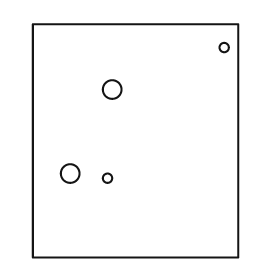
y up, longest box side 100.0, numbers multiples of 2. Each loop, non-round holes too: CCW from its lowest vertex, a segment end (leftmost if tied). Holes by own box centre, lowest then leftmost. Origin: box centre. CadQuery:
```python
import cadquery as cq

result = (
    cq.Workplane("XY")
    .moveTo(-44.0, -50.0)
    .lineTo(44.0, -50.0)
    .lineTo(44.0, 50.0)
    .lineTo(-44.0, 50.0)
    .close()
    .moveTo(-12.0, -16.0)
    .circle(2.0)
    .moveTo(-28.0, -14.0)
    .circle(4.0)
    .moveTo(-10.0, 22.0)
    .circle(4.0)
    .moveTo(38.0, 40.0)
    .circle(2.0)
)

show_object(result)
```